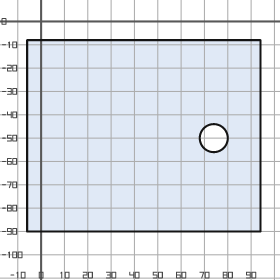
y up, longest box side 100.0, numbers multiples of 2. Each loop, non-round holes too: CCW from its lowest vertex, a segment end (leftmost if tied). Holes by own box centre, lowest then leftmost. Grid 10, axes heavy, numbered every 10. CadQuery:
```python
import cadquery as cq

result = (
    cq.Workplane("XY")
    .moveTo(-6.0, -90.0)
    .lineTo(94.0, -90.0)
    .lineTo(94.0, -8.0)
    .lineTo(-6.0, -8.0)
    .close()
    .moveTo(74.0, -50.0)
    .circle(6.0)
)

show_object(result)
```